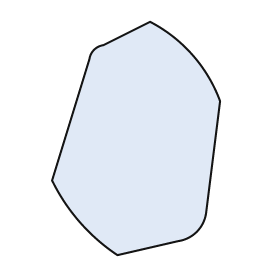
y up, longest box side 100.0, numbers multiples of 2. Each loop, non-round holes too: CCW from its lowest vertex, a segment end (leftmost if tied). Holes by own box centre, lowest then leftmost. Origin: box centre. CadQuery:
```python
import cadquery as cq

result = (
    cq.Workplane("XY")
    .moveTo(-8.0, -50.0)
    .lineTo(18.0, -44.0)
    .threePointArc((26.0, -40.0), (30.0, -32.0))
    .lineTo(36.0, 16.0)
    .threePointArc((24.0, 36.0), (6.0, 50.0))
    .lineTo(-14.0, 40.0)
    .threePointArc((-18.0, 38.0), (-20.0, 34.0))
    .lineTo(-36.0, -18.0)
    .threePointArc((-24.0, -36.0), (-8.0, -50.0))
    .close()
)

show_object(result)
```